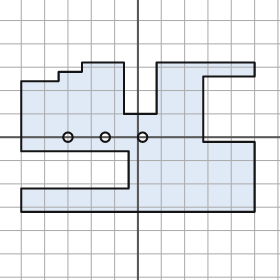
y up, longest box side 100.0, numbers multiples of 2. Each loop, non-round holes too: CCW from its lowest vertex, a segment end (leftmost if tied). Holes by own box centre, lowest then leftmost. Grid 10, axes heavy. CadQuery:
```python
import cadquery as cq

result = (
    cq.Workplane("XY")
    .moveTo(-50.0, -32.0)
    .lineTo(50.0, -32.0)
    .lineTo(50.0, -2.0)
    .lineTo(28.0, -2.0)
    .lineTo(28.0, 26.0)
    .lineTo(50.0, 26.0)
    .lineTo(50.0, 32.0)
    .lineTo(8.0, 32.0)
    .lineTo(8.0, 10.0)
    .lineTo(-6.0, 10.0)
    .lineTo(-6.0, 32.0)
    .lineTo(-24.0, 32.0)
    .lineTo(-24.0, 28.0)
    .lineTo(-34.0, 28.0)
    .lineTo(-34.0, 24.0)
    .lineTo(-50.0, 24.0)
    .lineTo(-50.0, -6.0)
    .lineTo(-4.0, -6.0)
    .lineTo(-4.0, -22.0)
    .lineTo(-50.0, -22.0)
    .close()
    .moveTo(-30.0, 0.0)
    .circle(2.0)
    .moveTo(-14.0, 0.0)
    .circle(2.0)
    .moveTo(2.0, 0.0)
    .circle(2.0)
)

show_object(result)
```